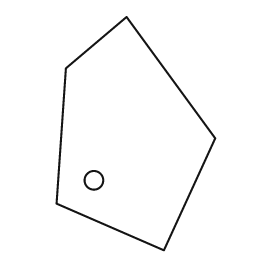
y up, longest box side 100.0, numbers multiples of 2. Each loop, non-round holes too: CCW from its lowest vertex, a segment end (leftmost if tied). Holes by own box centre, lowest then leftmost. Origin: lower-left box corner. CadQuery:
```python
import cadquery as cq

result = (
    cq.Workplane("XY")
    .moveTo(46.0, 0.0)
    .lineTo(68.0, 48.0)
    .lineTo(30.0, 100.0)
    .lineTo(4.0, 78.0)
    .lineTo(0.0, 20.0)
    .close()
    .moveTo(16.0, 30.0)
    .circle(4.0)
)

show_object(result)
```